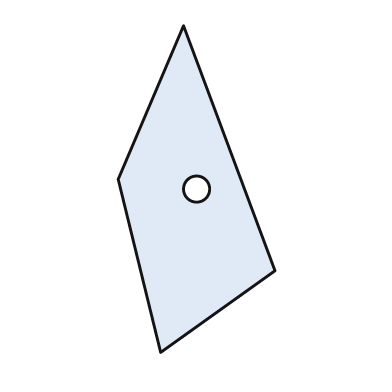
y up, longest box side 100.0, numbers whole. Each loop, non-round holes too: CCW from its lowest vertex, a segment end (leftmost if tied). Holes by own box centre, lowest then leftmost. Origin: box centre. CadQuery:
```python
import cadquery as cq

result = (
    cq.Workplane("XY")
    .moveTo(-11.0, -50.0)
    .lineTo(24.0, -25.0)
    .lineTo(-4.0, 50.0)
    .lineTo(-24.0, 3.0)
    .close()
    .moveTo(0.0, 0.0)
    .circle(4.0)
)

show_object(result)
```